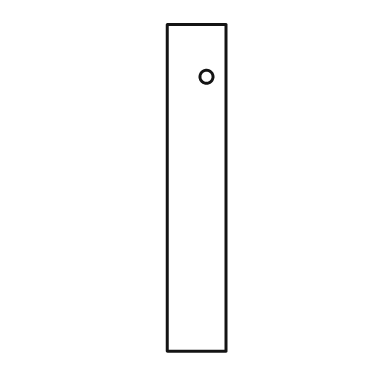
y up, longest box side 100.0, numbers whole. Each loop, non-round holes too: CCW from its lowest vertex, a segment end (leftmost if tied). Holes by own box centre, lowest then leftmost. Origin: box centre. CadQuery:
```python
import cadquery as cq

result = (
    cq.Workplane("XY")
    .moveTo(-9.0, -50.0)
    .lineTo(9.0, -50.0)
    .lineTo(9.0, 50.0)
    .lineTo(-9.0, 50.0)
    .close()
    .moveTo(3.0, 34.0)
    .circle(2.0)
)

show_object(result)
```